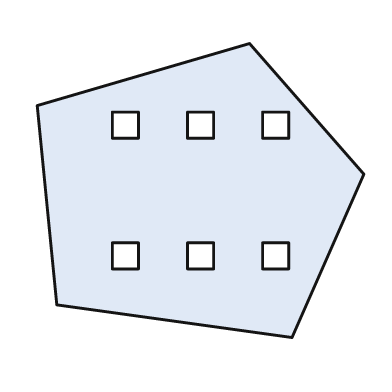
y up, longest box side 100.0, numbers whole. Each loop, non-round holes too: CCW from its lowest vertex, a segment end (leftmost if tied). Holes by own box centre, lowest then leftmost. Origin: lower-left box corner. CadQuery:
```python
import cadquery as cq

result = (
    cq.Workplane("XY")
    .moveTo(78.0, 0.0)
    .lineTo(100.0, 50.0)
    .lineTo(65.0, 90.0)
    .lineTo(0.0, 71.0)
    .lineTo(6.0, 10.0)
    .close()
    .moveTo(23.0, 21.0)
    .lineTo(31.0, 21.0)
    .lineTo(31.0, 29.0)
    .lineTo(23.0, 29.0)
    .close()
    .moveTo(46.0, 21.0)
    .lineTo(54.0, 21.0)
    .lineTo(54.0, 29.0)
    .lineTo(46.0, 29.0)
    .close()
    .moveTo(69.0, 21.0)
    .lineTo(77.0, 21.0)
    .lineTo(77.0, 29.0)
    .lineTo(69.0, 29.0)
    .close()
    .moveTo(23.0, 61.0)
    .lineTo(31.0, 61.0)
    .lineTo(31.0, 69.0)
    .lineTo(23.0, 69.0)
    .close()
    .moveTo(46.0, 61.0)
    .lineTo(54.0, 61.0)
    .lineTo(54.0, 69.0)
    .lineTo(46.0, 69.0)
    .close()
    .moveTo(69.0, 61.0)
    .lineTo(77.0, 61.0)
    .lineTo(77.0, 69.0)
    .lineTo(69.0, 69.0)
    .close()
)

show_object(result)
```